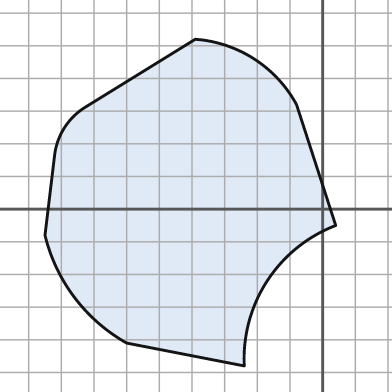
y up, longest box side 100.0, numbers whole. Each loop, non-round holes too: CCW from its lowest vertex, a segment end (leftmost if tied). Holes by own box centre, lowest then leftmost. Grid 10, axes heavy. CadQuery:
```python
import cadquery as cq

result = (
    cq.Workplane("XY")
    .moveTo(-24.0, -48.0)
    .threePointArc((-17.0, -22.0), (4.0, -5.0))
    .lineTo(-8.0, 32.0)
    .threePointArc((-21.0, 46.0), (-39.0, 52.0))
    .lineTo(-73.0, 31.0)
    .threePointArc((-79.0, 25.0), (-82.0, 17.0))
    .lineTo(-85.0, -8.0)
    .threePointArc((-76.0, -27.0), (-60.0, -41.0))
    .close()
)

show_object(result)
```